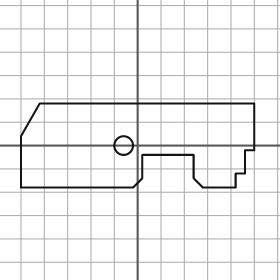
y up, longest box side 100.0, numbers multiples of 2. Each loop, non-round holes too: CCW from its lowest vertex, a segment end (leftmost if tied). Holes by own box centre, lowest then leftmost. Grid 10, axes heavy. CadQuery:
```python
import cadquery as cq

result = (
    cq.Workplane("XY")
    .moveTo(-50.0, -18.0)
    .lineTo(-2.0, -18.0)
    .lineTo(2.0, -14.0)
    .lineTo(2.0, -4.0)
    .lineTo(24.0, -4.0)
    .lineTo(24.0, -14.0)
    .lineTo(28.0, -18.0)
    .lineTo(42.0, -18.0)
    .lineTo(42.0, -12.0)
    .lineTo(46.0, -12.0)
    .lineTo(46.0, -2.0)
    .lineTo(50.0, -2.0)
    .lineTo(50.0, 18.0)
    .lineTo(-42.0, 18.0)
    .lineTo(-50.0, 4.0)
    .close()
    .moveTo(-6.0, 0.0)
    .circle(4.0)
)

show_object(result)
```